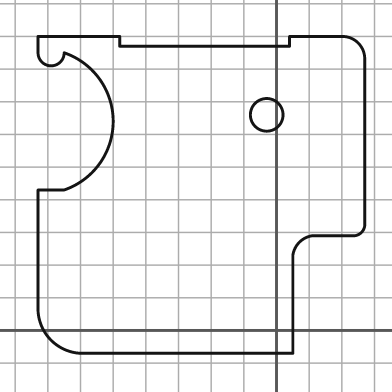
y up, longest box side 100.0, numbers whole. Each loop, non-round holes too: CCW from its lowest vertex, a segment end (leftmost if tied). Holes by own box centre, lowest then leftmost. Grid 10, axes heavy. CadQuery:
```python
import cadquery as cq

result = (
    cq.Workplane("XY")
    .moveTo(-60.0, -7.0)
    .lineTo(5.0, -7.0)
    .lineTo(5.0, 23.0)
    .threePointArc((7.0, 27.0), (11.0, 29.0))
    .lineTo(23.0, 29.0)
    .threePointArc((26.0, 30.0), (27.0, 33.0))
    .lineTo(27.0, 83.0)
    .threePointArc((25.0, 88.0), (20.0, 90.0))
    .lineTo(4.0, 90.0)
    .lineTo(4.0, 87.0)
    .lineTo(-48.0, 87.0)
    .lineTo(-48.0, 90.0)
    .lineTo(-73.0, 90.0)
    .lineTo(-73.0, 85.0)
    .threePointArc((-69.0, 81.0), (-65.0, 85.0))
    .threePointArc((-50.0, 64.0), (-65.0, 43.0))
    .lineTo(-73.0, 43.0)
    .lineTo(-73.0, 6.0)
    .threePointArc((-69.0, -3.0), (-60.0, -7.0))
    .close()
    .moveTo(-3.0, 66.0)
    .circle(5.0)
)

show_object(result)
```